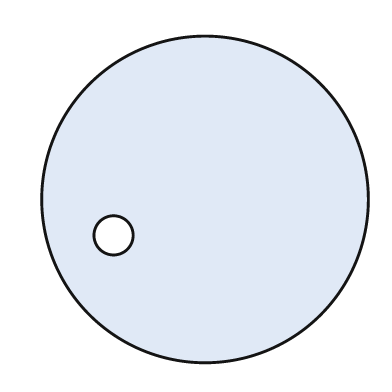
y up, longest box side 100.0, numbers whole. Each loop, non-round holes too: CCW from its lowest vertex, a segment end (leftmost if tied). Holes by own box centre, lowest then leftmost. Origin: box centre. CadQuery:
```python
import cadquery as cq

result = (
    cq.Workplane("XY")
    .moveTo(0.0, 0.0)
    .circle(50.0)
    .moveTo(-28.0, -11.0)
    .circle(6.0)
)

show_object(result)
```